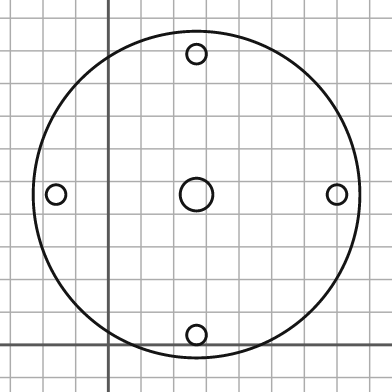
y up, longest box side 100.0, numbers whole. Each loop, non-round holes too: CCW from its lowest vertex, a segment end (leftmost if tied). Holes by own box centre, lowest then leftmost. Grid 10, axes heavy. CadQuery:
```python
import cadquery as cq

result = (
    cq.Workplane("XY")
    .moveTo(27.0, 46.0)
    .circle(50.0)
    .moveTo(27.0, 3.0)
    .circle(3.0)
    .moveTo(-16.0, 46.0)
    .circle(3.0)
    .moveTo(27.0, 46.0)
    .circle(5.0)
    .moveTo(70.0, 46.0)
    .circle(3.0)
    .moveTo(27.0, 89.0)
    .circle(3.0)
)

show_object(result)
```